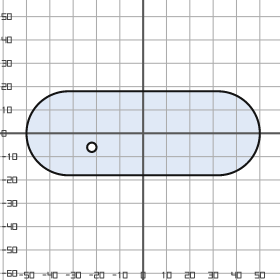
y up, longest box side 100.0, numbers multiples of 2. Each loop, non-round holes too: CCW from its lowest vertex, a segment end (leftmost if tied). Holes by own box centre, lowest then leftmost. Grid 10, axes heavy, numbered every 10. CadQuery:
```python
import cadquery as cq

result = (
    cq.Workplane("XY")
    .moveTo(-32.0, -18.0)
    .lineTo(32.0, -18.0)
    .threePointArc((50.0, 0.0), (32.0, 18.0))
    .lineTo(-32.0, 18.0)
    .threePointArc((-50.0, 0.0), (-32.0, -18.0))
    .close()
    .moveTo(-22.0, -6.0)
    .circle(2.0)
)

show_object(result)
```